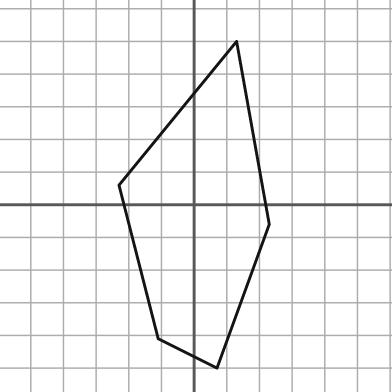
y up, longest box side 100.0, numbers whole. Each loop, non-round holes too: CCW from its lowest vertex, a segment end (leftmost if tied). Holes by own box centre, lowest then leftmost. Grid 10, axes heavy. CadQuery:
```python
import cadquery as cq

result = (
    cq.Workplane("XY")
    .moveTo(7.0, -50.0)
    .lineTo(23.0, -6.0)
    .lineTo(13.0, 50.0)
    .lineTo(-23.0, 6.0)
    .lineTo(-11.0, -41.0)
    .close()
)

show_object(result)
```